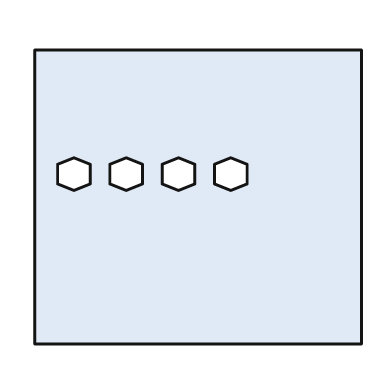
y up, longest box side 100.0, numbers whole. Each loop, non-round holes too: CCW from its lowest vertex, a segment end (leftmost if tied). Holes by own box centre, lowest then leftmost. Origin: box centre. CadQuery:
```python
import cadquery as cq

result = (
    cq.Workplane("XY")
    .moveTo(-50.0, -45.0)
    .lineTo(50.0, -45.0)
    .lineTo(50.0, 45.0)
    .lineTo(-50.0, 45.0)
    .close()
    .moveTo(-38.0, 2.0)
    .lineTo(-33.0, 4.0)
    .lineTo(-33.0, 10.0)
    .lineTo(-38.0, 12.0)
    .lineTo(-43.0, 10.0)
    .lineTo(-43.0, 4.0)
    .close()
    .moveTo(-22.0, 2.0)
    .lineTo(-17.0, 4.0)
    .lineTo(-17.0, 10.0)
    .lineTo(-22.0, 12.0)
    .lineTo(-27.0, 10.0)
    .lineTo(-27.0, 4.0)
    .close()
    .moveTo(-6.0, 2.0)
    .lineTo(-1.0, 4.0)
    .lineTo(-1.0, 10.0)
    .lineTo(-6.0, 12.0)
    .lineTo(-11.0, 10.0)
    .lineTo(-11.0, 4.0)
    .close()
    .moveTo(10.0, 2.0)
    .lineTo(15.0, 4.0)
    .lineTo(15.0, 10.0)
    .lineTo(10.0, 12.0)
    .lineTo(5.0, 10.0)
    .lineTo(5.0, 4.0)
    .close()
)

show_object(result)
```